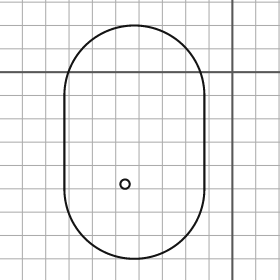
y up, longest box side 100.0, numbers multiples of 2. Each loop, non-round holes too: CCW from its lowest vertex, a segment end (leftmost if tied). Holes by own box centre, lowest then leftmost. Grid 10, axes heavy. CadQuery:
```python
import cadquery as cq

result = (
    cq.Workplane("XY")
    .moveTo(-72.0, -50.0)
    .threePointArc((-42.0, -80.0), (-12.0, -50.0))
    .lineTo(-12.0, -10.0)
    .threePointArc((-42.0, 20.0), (-72.0, -10.0))
    .close()
    .moveTo(-46.0, -48.0)
    .circle(2.0)
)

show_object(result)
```